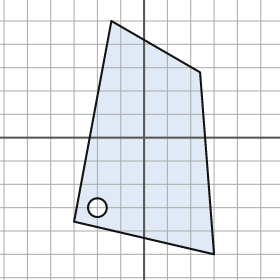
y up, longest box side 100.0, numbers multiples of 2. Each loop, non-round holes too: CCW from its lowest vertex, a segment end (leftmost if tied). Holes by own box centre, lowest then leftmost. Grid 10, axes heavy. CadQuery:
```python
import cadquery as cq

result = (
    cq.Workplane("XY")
    .moveTo(30.0, -50.0)
    .lineTo(24.0, 28.0)
    .lineTo(-14.0, 50.0)
    .lineTo(-30.0, -36.0)
    .close()
    .moveTo(-20.0, -30.0)
    .circle(4.0)
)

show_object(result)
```